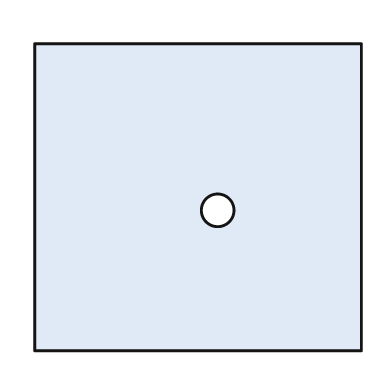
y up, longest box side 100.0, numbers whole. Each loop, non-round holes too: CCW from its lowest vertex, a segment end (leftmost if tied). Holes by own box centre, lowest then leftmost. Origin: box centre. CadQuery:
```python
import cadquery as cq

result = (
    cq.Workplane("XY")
    .moveTo(-50.0, -47.0)
    .lineTo(50.0, -47.0)
    .lineTo(50.0, 47.0)
    .lineTo(-50.0, 47.0)
    .close()
    .moveTo(6.0, -4.0)
    .circle(5.0)
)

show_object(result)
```